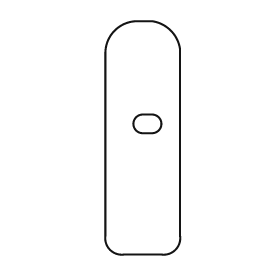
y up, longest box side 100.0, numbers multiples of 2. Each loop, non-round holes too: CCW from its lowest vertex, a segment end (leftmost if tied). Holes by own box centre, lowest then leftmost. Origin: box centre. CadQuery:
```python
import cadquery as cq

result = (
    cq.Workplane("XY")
    .moveTo(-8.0, -50.0)
    .lineTo(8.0, -50.0)
    .threePointArc((14.0, -48.0), (16.0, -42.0))
    .lineTo(16.0, 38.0)
    .threePointArc((12.0, 46.0), (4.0, 50.0))
    .lineTo(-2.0, 50.0)
    .threePointArc((-12.0, 46.0), (-16.0, 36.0))
    .lineTo(-16.0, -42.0)
    .threePointArc((-14.0, -48.0), (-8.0, -50.0))
    .close()
    .moveTo(0.0, 2.0)
    .lineTo(4.0, 2.0)
    .threePointArc((8.0, 6.0), (4.0, 10.0))
    .lineTo(0.0, 10.0)
    .threePointArc((-4.0, 6.0), (0.0, 2.0))
    .close()
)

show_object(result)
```